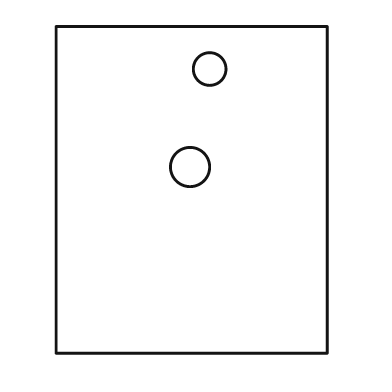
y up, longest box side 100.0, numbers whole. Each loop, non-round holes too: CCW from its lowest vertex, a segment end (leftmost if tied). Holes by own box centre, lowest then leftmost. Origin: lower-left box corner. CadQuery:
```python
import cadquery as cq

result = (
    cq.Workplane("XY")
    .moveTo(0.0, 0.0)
    .lineTo(83.0, 0.0)
    .lineTo(83.0, 100.0)
    .lineTo(0.0, 100.0)
    .close()
    .moveTo(41.0, 57.0)
    .circle(6.0)
    .moveTo(47.0, 87.0)
    .circle(5.0)
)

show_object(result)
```